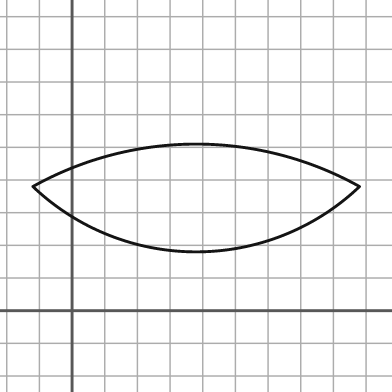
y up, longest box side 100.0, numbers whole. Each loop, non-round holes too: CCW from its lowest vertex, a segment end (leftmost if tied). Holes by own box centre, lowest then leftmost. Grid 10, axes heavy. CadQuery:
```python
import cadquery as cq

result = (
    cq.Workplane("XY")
    .moveTo(-12.0, 38.0)
    .threePointArc((38.0, 18.0), (88.0, 38.0))
    .threePointArc((38.0, 51.0), (-12.0, 38.0))
    .close()
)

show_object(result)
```